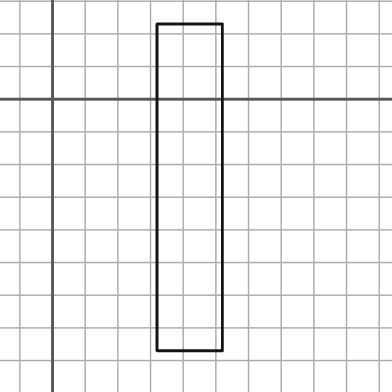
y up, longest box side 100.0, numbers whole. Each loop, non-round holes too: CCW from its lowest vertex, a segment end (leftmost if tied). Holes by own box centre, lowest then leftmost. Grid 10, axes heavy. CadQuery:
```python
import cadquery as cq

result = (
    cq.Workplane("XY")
    .moveTo(32.0, -77.0)
    .lineTo(52.0, -77.0)
    .lineTo(52.0, 23.0)
    .lineTo(32.0, 23.0)
    .close()
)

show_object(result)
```